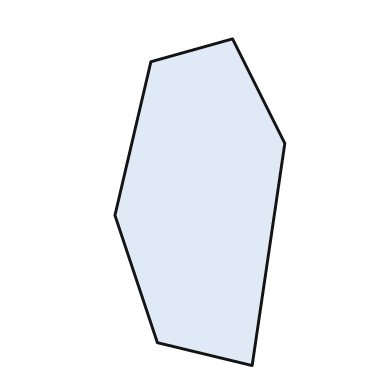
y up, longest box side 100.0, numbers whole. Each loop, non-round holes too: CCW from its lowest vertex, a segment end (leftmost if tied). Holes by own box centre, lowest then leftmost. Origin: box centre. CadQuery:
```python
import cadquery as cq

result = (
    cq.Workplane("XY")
    .moveTo(16.0, -50.0)
    .lineTo(26.0, 18.0)
    .lineTo(10.0, 50.0)
    .lineTo(-15.0, 43.0)
    .lineTo(-26.0, -4.0)
    .lineTo(-13.0, -43.0)
    .close()
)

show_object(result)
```